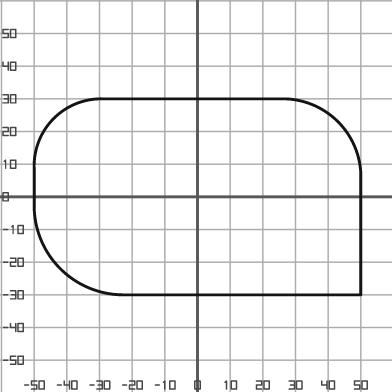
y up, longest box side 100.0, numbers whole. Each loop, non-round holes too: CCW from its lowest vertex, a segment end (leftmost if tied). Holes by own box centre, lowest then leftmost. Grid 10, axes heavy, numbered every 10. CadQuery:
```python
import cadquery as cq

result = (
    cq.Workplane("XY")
    .moveTo(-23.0, -30.0)
    .lineTo(50.0, -30.0)
    .lineTo(50.0, 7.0)
    .threePointArc((43.0, 23.0), (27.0, 30.0))
    .lineTo(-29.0, 30.0)
    .threePointArc((-44.0, 24.0), (-50.0, 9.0))
    .lineTo(-50.0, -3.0)
    .threePointArc((-42.0, -22.0), (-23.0, -30.0))
    .close()
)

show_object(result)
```